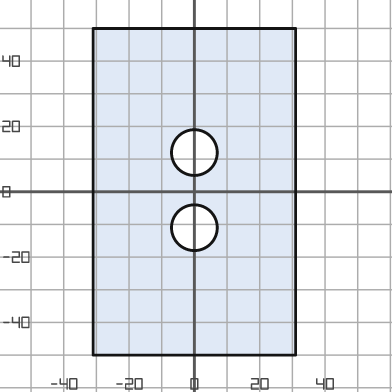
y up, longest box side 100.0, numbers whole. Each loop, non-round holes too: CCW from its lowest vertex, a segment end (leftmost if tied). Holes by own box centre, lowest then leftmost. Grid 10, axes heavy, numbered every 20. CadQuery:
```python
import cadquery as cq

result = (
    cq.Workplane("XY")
    .moveTo(-31.0, -50.0)
    .lineTo(31.0, -50.0)
    .lineTo(31.0, 50.0)
    .lineTo(-31.0, 50.0)
    .close()
    .moveTo(0.0, -11.0)
    .circle(7.0)
    .moveTo(0.0, 12.0)
    .circle(7.0)
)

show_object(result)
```